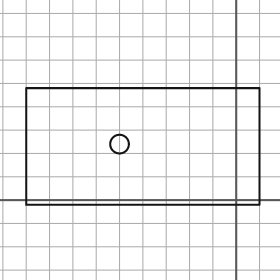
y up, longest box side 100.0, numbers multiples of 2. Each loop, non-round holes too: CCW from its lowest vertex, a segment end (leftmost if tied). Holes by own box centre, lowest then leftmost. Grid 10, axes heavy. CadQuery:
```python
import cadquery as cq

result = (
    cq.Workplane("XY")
    .moveTo(-90.0, -2.0)
    .lineTo(10.0, -2.0)
    .lineTo(10.0, 48.0)
    .lineTo(-90.0, 48.0)
    .close()
    .moveTo(-50.0, 24.0)
    .circle(4.0)
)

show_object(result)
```